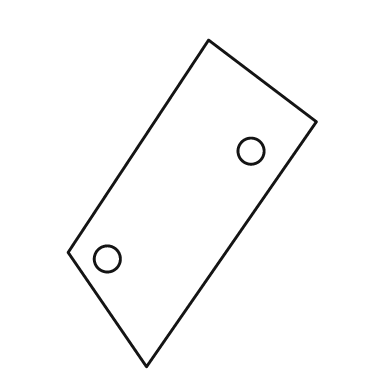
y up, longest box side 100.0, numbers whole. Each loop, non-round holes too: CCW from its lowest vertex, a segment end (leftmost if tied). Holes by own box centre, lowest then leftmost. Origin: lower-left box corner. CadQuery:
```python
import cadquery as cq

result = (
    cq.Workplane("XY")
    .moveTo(24.0, 0.0)
    .lineTo(76.0, 75.0)
    .lineTo(43.0, 100.0)
    .lineTo(0.0, 35.0)
    .close()
    .moveTo(12.0, 33.0)
    .circle(4.0)
    .moveTo(56.0, 66.0)
    .circle(4.0)
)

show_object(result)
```